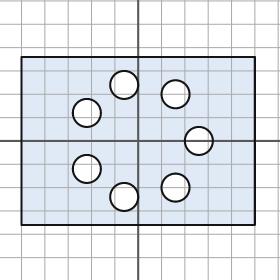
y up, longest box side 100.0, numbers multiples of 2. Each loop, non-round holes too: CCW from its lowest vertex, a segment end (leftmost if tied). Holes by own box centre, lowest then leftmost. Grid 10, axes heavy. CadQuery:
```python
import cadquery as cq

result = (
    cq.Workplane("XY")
    .moveTo(-50.0, -36.0)
    .lineTo(50.0, -36.0)
    .lineTo(50.0, 36.0)
    .lineTo(-50.0, 36.0)
    .close()
    .moveTo(-6.0, -24.0)
    .circle(6.0)
    .moveTo(16.0, -20.0)
    .circle(6.0)
    .moveTo(-22.0, -12.0)
    .circle(6.0)
    .moveTo(26.0, 0.0)
    .circle(6.0)
    .moveTo(-22.0, 12.0)
    .circle(6.0)
    .moveTo(16.0, 20.0)
    .circle(6.0)
    .moveTo(-6.0, 24.0)
    .circle(6.0)
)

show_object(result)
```